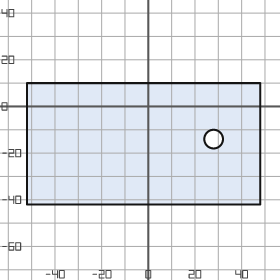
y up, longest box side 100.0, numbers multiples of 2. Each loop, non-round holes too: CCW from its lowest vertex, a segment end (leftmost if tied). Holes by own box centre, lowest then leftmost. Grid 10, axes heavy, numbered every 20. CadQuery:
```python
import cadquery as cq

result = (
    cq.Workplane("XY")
    .moveTo(-52.0, -42.0)
    .lineTo(48.0, -42.0)
    .lineTo(48.0, 10.0)
    .lineTo(-52.0, 10.0)
    .close()
    .moveTo(28.0, -14.0)
    .circle(4.0)
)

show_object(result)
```